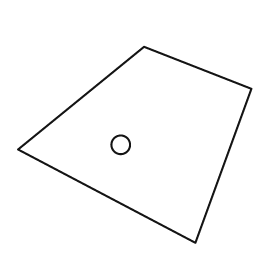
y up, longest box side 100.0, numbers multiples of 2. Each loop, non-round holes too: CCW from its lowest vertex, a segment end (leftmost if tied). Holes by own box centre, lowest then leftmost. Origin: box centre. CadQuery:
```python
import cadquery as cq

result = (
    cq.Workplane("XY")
    .moveTo(26.0, -42.0)
    .lineTo(50.0, 24.0)
    .lineTo(4.0, 42.0)
    .lineTo(-50.0, -2.0)
    .close()
    .moveTo(-6.0, 0.0)
    .circle(4.0)
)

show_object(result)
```